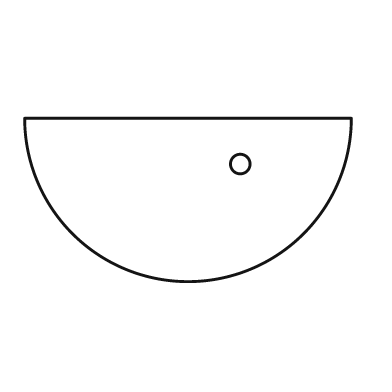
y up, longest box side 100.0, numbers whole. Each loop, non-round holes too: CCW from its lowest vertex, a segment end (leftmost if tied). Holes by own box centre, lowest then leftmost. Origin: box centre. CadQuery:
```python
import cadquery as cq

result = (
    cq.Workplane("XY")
    .moveTo(-50.0, 25.0)
    .threePointArc((0.0, -25.0), (50.0, 25.0))
    .close()
    .moveTo(16.0, 11.0)
    .circle(3.0)
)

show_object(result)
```